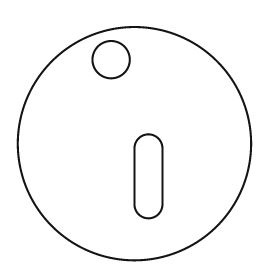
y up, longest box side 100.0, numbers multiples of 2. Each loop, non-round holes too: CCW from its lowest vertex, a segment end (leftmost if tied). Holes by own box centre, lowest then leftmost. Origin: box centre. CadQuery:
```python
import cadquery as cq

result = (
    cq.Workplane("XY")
    .moveTo(0.0, 0.0)
    .circle(50.0)
    .moveTo(0.0, -26.0)
    .threePointArc((6.0, -32.0), (12.0, -26.0))
    .lineTo(12.0, -2.0)
    .threePointArc((6.0, 4.0), (0.0, -2.0))
    .close()
    .moveTo(-10.0, 36.0)
    .circle(8.0)
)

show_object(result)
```